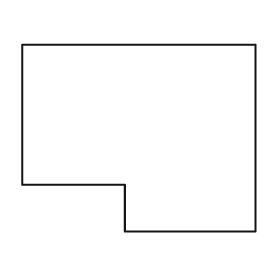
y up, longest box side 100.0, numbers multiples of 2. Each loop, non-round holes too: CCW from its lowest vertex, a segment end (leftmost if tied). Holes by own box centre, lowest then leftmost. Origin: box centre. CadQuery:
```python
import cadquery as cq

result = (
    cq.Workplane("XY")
    .moveTo(-6.0, -40.0)
    .lineTo(50.0, -40.0)
    .lineTo(50.0, 40.0)
    .lineTo(-50.0, 40.0)
    .lineTo(-50.0, -20.0)
    .lineTo(-6.0, -20.0)
    .close()
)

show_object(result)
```